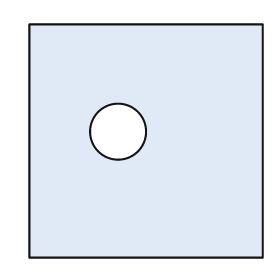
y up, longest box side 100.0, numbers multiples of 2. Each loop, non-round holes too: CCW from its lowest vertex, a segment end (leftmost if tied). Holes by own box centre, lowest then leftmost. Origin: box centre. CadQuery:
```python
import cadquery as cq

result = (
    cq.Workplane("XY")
    .moveTo(-50.0, -50.0)
    .lineTo(50.0, -50.0)
    .lineTo(50.0, 50.0)
    .lineTo(-50.0, 50.0)
    .close()
    .moveTo(-12.0, 4.0)
    .circle(12.0)
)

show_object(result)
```